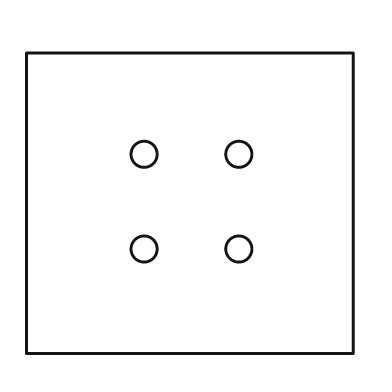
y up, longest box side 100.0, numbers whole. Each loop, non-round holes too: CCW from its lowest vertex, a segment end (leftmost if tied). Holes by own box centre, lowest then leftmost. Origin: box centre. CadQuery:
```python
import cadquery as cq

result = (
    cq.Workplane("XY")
    .moveTo(-50.0, -46.0)
    .lineTo(50.0, -46.0)
    .lineTo(50.0, 46.0)
    .lineTo(-50.0, 46.0)
    .close()
    .moveTo(-14.0, -14.0)
    .circle(4.0)
    .moveTo(15.0, -14.0)
    .circle(4.0)
    .moveTo(-14.0, 15.0)
    .circle(4.0)
    .moveTo(15.0, 15.0)
    .circle(4.0)
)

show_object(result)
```